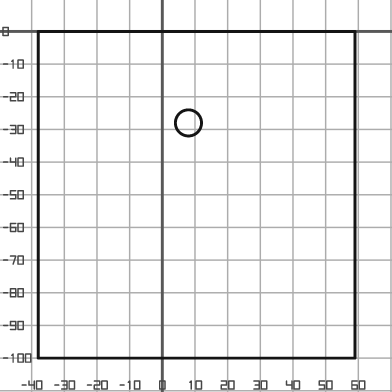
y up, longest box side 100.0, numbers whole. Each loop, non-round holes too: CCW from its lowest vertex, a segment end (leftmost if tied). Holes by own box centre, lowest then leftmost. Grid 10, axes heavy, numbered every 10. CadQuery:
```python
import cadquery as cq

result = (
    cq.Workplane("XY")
    .moveTo(-38.0, -100.0)
    .lineTo(59.0, -100.0)
    .lineTo(59.0, 0.0)
    .lineTo(-38.0, 0.0)
    .close()
    .moveTo(8.0, -28.0)
    .circle(4.0)
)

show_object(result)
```